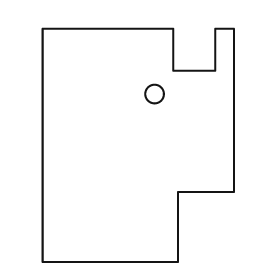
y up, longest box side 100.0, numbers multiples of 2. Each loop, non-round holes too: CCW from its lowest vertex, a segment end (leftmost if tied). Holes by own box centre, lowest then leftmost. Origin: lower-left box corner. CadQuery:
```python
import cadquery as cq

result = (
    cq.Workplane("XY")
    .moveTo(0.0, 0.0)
    .lineTo(58.0, 0.0)
    .lineTo(58.0, 30.0)
    .lineTo(82.0, 30.0)
    .lineTo(82.0, 100.0)
    .lineTo(74.0, 100.0)
    .lineTo(74.0, 82.0)
    .lineTo(56.0, 82.0)
    .lineTo(56.0, 100.0)
    .lineTo(0.0, 100.0)
    .close()
    .moveTo(48.0, 72.0)
    .circle(4.0)
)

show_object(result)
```